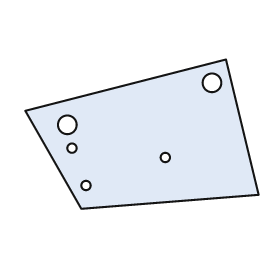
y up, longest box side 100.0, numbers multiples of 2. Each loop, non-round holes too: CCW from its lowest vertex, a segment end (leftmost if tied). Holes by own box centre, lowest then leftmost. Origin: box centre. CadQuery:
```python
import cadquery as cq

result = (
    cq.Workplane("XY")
    .moveTo(-26.0, -32.0)
    .lineTo(50.0, -26.0)
    .lineTo(36.0, 32.0)
    .lineTo(-50.0, 10.0)
    .close()
    .moveTo(-24.0, -22.0)
    .circle(2.0)
    .moveTo(10.0, -10.0)
    .circle(2.0)
    .moveTo(-30.0, -6.0)
    .circle(2.0)
    .moveTo(-32.0, 4.0)
    .circle(4.0)
    .moveTo(30.0, 22.0)
    .circle(4.0)
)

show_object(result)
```